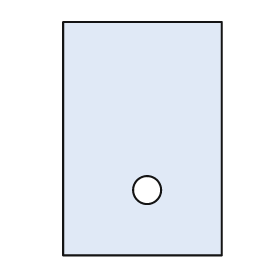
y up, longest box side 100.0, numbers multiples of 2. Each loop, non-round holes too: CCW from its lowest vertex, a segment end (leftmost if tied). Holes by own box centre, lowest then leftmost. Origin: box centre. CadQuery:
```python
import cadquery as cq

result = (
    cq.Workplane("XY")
    .moveTo(-34.0, -50.0)
    .lineTo(34.0, -50.0)
    .lineTo(34.0, 50.0)
    .lineTo(-34.0, 50.0)
    .close()
    .moveTo(2.0, -22.0)
    .circle(6.0)
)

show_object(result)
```